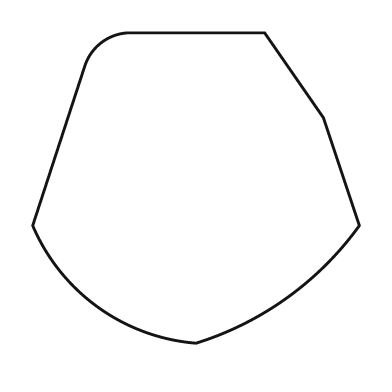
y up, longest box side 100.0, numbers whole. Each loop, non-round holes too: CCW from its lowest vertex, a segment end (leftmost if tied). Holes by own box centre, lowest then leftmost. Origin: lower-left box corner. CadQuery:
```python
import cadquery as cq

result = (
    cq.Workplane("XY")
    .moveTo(50.0, 0.0)
    .threePointArc((78.0, 14.0), (100.0, 36.0))
    .lineTo(89.0, 69.0)
    .lineTo(71.0, 95.0)
    .lineTo(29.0, 95.0)
    .threePointArc((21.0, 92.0), (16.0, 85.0))
    .lineTo(0.0, 36.0)
    .threePointArc((20.0, 11.0), (50.0, 0.0))
    .close()
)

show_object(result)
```